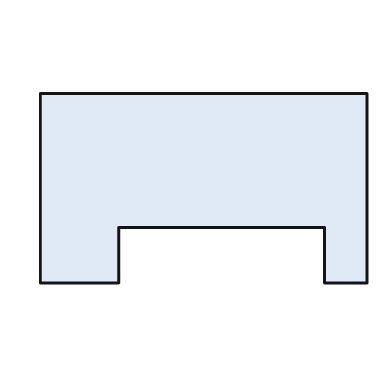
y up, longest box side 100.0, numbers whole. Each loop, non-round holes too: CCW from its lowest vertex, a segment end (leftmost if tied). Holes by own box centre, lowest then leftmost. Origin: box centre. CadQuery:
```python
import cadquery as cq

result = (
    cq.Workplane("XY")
    .moveTo(-50.0, -29.0)
    .lineTo(-26.0, -29.0)
    .lineTo(-26.0, -12.0)
    .lineTo(37.0, -12.0)
    .lineTo(37.0, -29.0)
    .lineTo(50.0, -29.0)
    .lineTo(50.0, 29.0)
    .lineTo(-50.0, 29.0)
    .close()
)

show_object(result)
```